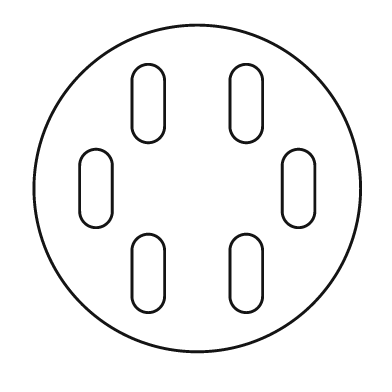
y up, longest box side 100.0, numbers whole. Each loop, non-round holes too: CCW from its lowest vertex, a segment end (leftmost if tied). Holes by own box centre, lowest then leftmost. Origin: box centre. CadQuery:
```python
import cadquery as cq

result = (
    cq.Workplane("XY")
    .moveTo(0.0, 0.0)
    .circle(50.0)
    .moveTo(-20.0, -33.0)
    .threePointArc((-15.0, -38.0), (-10.0, -33.0))
    .lineTo(-10.0, -19.0)
    .threePointArc((-15.0, -14.0), (-20.0, -19.0))
    .close()
    .moveTo(10.0, -33.0)
    .threePointArc((15.0, -38.0), (20.0, -33.0))
    .lineTo(20.0, -19.0)
    .threePointArc((15.0, -14.0), (10.0, -19.0))
    .close()
    .moveTo(-36.0, -7.0)
    .threePointArc((-31.0, -12.0), (-26.0, -7.0))
    .lineTo(-26.0, 7.0)
    .threePointArc((-31.0, 12.0), (-36.0, 7.0))
    .close()
    .moveTo(26.0, -7.0)
    .threePointArc((31.0, -12.0), (36.0, -7.0))
    .lineTo(36.0, 7.0)
    .threePointArc((31.0, 12.0), (26.0, 7.0))
    .close()
    .moveTo(-20.0, 19.0)
    .threePointArc((-15.0, 14.0), (-10.0, 19.0))
    .lineTo(-10.0, 33.0)
    .threePointArc((-15.0, 38.0), (-20.0, 33.0))
    .close()
    .moveTo(10.0, 19.0)
    .threePointArc((15.0, 14.0), (20.0, 19.0))
    .lineTo(20.0, 33.0)
    .threePointArc((15.0, 38.0), (10.0, 33.0))
    .close()
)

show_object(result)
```